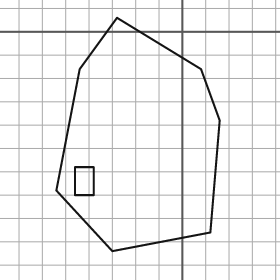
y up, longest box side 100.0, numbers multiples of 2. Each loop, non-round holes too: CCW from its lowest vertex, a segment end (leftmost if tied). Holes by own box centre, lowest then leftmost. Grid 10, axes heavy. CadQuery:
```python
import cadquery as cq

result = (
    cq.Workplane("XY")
    .moveTo(-30.0, -94.0)
    .lineTo(12.0, -86.0)
    .lineTo(16.0, -38.0)
    .lineTo(8.0, -16.0)
    .lineTo(-28.0, 6.0)
    .lineTo(-44.0, -16.0)
    .lineTo(-54.0, -68.0)
    .close()
    .moveTo(-46.0, -70.0)
    .lineTo(-38.0, -70.0)
    .lineTo(-38.0, -58.0)
    .lineTo(-46.0, -58.0)
    .close()
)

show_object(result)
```